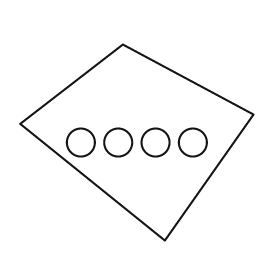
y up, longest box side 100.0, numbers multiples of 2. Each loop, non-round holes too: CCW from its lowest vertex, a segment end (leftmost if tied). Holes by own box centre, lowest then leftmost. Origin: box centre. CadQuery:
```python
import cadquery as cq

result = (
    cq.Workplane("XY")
    .moveTo(12.0, -42.0)
    .lineTo(50.0, 12.0)
    .lineTo(-6.0, 42.0)
    .lineTo(-50.0, 8.0)
    .close()
    .moveTo(-24.0, 0.0)
    .circle(6.0)
    .moveTo(-8.0, 0.0)
    .circle(6.0)
    .moveTo(8.0, 0.0)
    .circle(6.0)
    .moveTo(24.0, 0.0)
    .circle(6.0)
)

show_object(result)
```